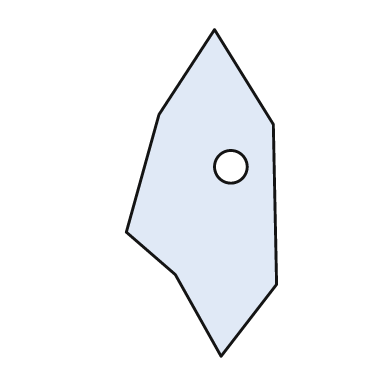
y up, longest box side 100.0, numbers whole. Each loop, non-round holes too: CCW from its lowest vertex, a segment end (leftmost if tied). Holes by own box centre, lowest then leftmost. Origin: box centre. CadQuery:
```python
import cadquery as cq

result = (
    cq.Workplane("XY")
    .moveTo(6.0, -50.0)
    .lineTo(23.0, -28.0)
    .lineTo(22.0, 21.0)
    .lineTo(4.0, 50.0)
    .lineTo(-13.0, 24.0)
    .lineTo(-23.0, -12.0)
    .lineTo(-8.0, -25.0)
    .close()
    .moveTo(9.0, 8.0)
    .circle(5.0)
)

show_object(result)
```